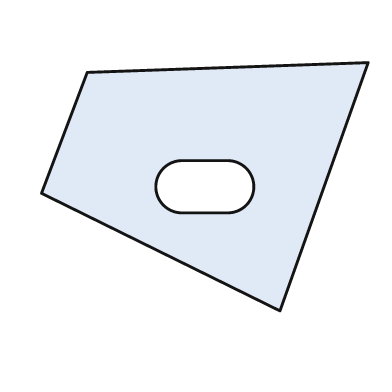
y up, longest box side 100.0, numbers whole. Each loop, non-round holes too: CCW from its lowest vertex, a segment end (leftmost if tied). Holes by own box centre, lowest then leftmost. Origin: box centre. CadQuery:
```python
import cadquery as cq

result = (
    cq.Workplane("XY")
    .moveTo(23.0, -38.0)
    .lineTo(50.0, 38.0)
    .lineTo(-36.0, 35.0)
    .lineTo(-50.0, -2.0)
    .close()
    .moveTo(-7.0, -8.0)
    .lineTo(7.0, -8.0)
    .threePointArc((15.0, 0.0), (7.0, 8.0))
    .lineTo(-7.0, 8.0)
    .threePointArc((-15.0, 0.0), (-7.0, -8.0))
    .close()
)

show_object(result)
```